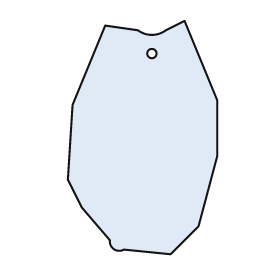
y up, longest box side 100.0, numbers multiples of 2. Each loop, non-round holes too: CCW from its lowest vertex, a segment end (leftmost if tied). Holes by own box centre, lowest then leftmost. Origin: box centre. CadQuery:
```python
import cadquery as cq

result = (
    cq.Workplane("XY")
    .moveTo(12.0, -50.0)
    .lineTo(24.0, -38.0)
    .lineTo(32.0, -8.0)
    .lineTo(32.0, 16.0)
    .lineTo(18.0, 50.0)
    .lineTo(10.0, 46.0)
    .threePointArc((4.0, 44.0), (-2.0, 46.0))
    .lineTo(-16.0, 48.0)
    .lineTo(-30.0, 14.0)
    .lineTo(-32.0, -18.0)
    .lineTo(-26.0, -30.0)
    .lineTo(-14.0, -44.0)
    .threePointArc((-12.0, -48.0), (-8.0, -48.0))
    .close()
    .moveTo(4.0, 36.0)
    .circle(2.0)
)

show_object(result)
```